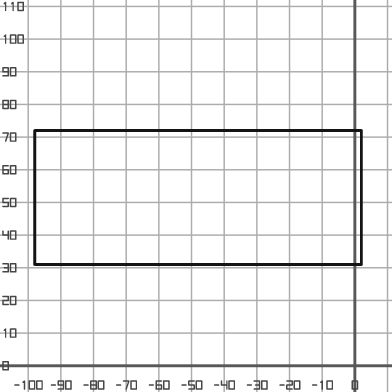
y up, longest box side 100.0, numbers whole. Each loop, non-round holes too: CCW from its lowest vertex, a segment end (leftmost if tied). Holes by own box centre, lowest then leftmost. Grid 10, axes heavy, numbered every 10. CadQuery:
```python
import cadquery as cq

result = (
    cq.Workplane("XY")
    .moveTo(-98.0, 31.0)
    .lineTo(2.0, 31.0)
    .lineTo(2.0, 72.0)
    .lineTo(-98.0, 72.0)
    .close()
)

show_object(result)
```